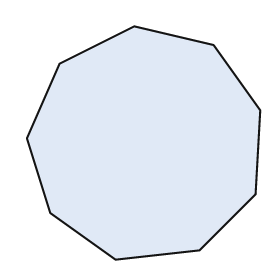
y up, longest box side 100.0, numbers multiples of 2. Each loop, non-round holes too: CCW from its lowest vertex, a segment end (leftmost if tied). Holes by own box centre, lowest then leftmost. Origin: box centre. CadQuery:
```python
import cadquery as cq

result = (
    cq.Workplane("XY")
    .moveTo(-12.0, -50.0)
    .lineTo(24.0, -46.0)
    .lineTo(48.0, -22.0)
    .lineTo(50.0, 14.0)
    .lineTo(30.0, 42.0)
    .lineTo(-4.0, 50.0)
    .lineTo(-36.0, 34.0)
    .lineTo(-50.0, 2.0)
    .lineTo(-40.0, -30.0)
    .close()
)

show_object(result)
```